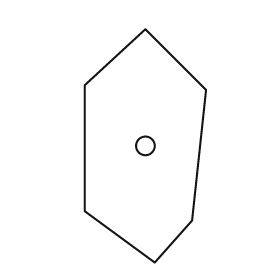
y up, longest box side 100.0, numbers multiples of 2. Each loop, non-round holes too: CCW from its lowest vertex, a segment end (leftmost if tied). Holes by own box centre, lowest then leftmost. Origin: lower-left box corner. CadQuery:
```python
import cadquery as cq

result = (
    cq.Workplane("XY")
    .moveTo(30.0, 0.0)
    .lineTo(46.0, 18.0)
    .lineTo(52.0, 74.0)
    .lineTo(26.0, 100.0)
    .lineTo(0.0, 76.0)
    .lineTo(0.0, 22.0)
    .close()
    .moveTo(26.0, 50.0)
    .circle(4.0)
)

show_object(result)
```